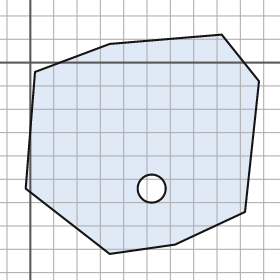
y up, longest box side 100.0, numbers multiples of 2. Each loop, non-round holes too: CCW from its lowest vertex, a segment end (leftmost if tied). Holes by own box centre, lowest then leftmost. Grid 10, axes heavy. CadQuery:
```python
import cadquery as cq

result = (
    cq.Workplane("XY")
    .moveTo(34.0, -82.0)
    .lineTo(62.0, -78.0)
    .lineTo(92.0, -64.0)
    .lineTo(98.0, -8.0)
    .lineTo(82.0, 12.0)
    .lineTo(34.0, 8.0)
    .lineTo(2.0, -4.0)
    .lineTo(-2.0, -54.0)
    .close()
    .moveTo(52.0, -54.0)
    .circle(6.0)
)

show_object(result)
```